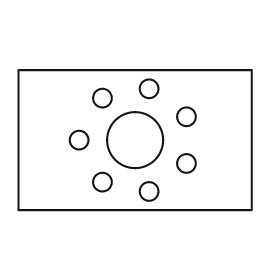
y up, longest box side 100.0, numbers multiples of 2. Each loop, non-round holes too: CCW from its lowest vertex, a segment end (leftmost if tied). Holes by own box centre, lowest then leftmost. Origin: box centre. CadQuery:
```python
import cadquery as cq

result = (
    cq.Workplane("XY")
    .moveTo(-50.0, -30.0)
    .lineTo(50.0, -30.0)
    .lineTo(50.0, 30.0)
    .lineTo(-50.0, 30.0)
    .close()
    .moveTo(6.0, -22.0)
    .circle(4.0)
    .moveTo(-14.0, -18.0)
    .circle(4.0)
    .moveTo(22.0, -10.0)
    .circle(4.0)
    .moveTo(-24.0, 0.0)
    .circle(4.0)
    .moveTo(0.0, 0.0)
    .circle(12.0)
    .moveTo(22.0, 10.0)
    .circle(4.0)
    .moveTo(-14.0, 18.0)
    .circle(4.0)
    .moveTo(6.0, 22.0)
    .circle(4.0)
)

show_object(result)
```